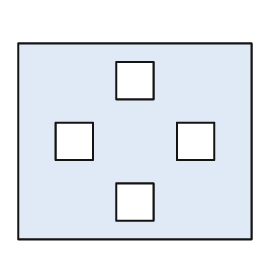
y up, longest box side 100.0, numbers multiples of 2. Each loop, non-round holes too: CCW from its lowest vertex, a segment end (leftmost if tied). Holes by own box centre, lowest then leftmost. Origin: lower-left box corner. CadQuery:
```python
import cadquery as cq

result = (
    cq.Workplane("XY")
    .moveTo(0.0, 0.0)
    .lineTo(100.0, 0.0)
    .lineTo(100.0, 84.0)
    .lineTo(0.0, 84.0)
    .close()
    .moveTo(42.0, 8.0)
    .lineTo(58.0, 8.0)
    .lineTo(58.0, 24.0)
    .lineTo(42.0, 24.0)
    .close()
    .moveTo(16.0, 34.0)
    .lineTo(32.0, 34.0)
    .lineTo(32.0, 50.0)
    .lineTo(16.0, 50.0)
    .close()
    .moveTo(68.0, 34.0)
    .lineTo(84.0, 34.0)
    .lineTo(84.0, 50.0)
    .lineTo(68.0, 50.0)
    .close()
    .moveTo(42.0, 60.0)
    .lineTo(58.0, 60.0)
    .lineTo(58.0, 76.0)
    .lineTo(42.0, 76.0)
    .close()
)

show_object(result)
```